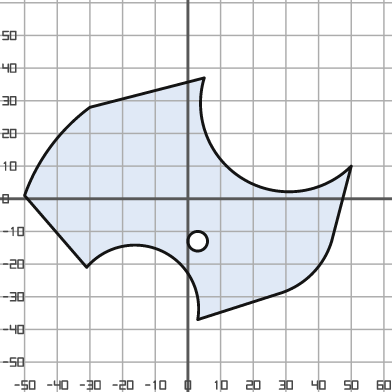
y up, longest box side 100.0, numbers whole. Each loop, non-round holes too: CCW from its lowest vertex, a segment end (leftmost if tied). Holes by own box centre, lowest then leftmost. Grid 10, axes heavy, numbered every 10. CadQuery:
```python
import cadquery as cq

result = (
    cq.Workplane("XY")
    .moveTo(3.0, -37.0)
    .lineTo(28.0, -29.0)
    .threePointArc((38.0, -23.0), (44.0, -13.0))
    .lineTo(50.0, 10.0)
    .threePointArc((17.0, 6.0), (5.0, 37.0))
    .lineTo(-30.0, 28.0)
    .threePointArc((-42.0, 16.0), (-50.0, 1.0))
    .lineTo(-31.0, -21.0)
    .threePointArc((-8.0, -16.0), (3.0, -37.0))
    .close()
    .moveTo(3.0, -13.0)
    .circle(3.0)
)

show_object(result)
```